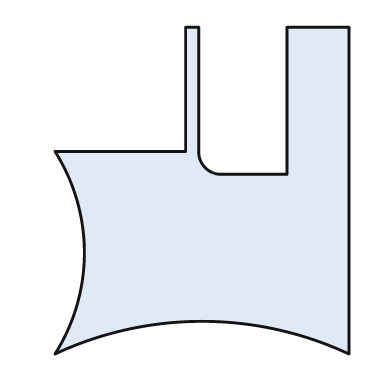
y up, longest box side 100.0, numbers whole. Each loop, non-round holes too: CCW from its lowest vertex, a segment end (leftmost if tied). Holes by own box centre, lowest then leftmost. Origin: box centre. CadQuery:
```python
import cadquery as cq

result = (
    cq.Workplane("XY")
    .moveTo(-45.0, -50.0)
    .threePointArc((0.0, -40.0), (45.0, -50.0))
    .lineTo(45.0, 50.0)
    .lineTo(26.0, 50.0)
    .lineTo(26.0, 5.0)
    .lineTo(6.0, 5.0)
    .threePointArc((1.0, 7.0), (-1.0, 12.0))
    .lineTo(-1.0, 50.0)
    .lineTo(-5.0, 50.0)
    .lineTo(-5.0, 12.0)
    .lineTo(-45.0, 12.0)
    .threePointArc((-36.0, -19.0), (-45.0, -50.0))
    .close()
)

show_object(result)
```